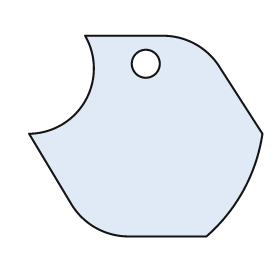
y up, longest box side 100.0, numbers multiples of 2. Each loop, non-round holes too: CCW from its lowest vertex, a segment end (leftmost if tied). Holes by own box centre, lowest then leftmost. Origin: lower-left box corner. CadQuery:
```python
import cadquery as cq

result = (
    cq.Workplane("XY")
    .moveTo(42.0, 0.0)
    .lineTo(76.0, 0.0)
    .threePointArc((92.0, 20.0), (100.0, 44.0))
    .lineTo(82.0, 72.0)
    .threePointArc((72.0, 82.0), (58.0, 86.0))
    .lineTo(24.0, 86.0)
    .threePointArc((24.0, 58.0), (0.0, 44.0))
    .lineTo(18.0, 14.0)
    .threePointArc((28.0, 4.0), (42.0, 0.0))
    .close()
    .moveTo(50.0, 74.0)
    .circle(6.0)
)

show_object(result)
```